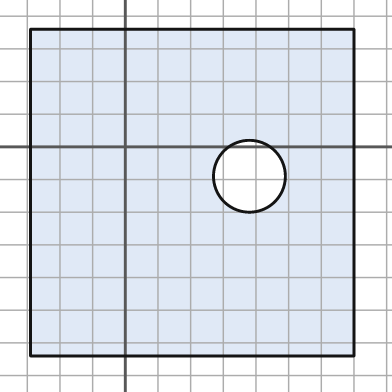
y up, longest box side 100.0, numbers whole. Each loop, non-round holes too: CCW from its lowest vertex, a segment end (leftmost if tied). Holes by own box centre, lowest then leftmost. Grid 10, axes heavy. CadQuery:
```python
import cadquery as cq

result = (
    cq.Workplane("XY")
    .moveTo(-29.0, -64.0)
    .lineTo(70.0, -64.0)
    .lineTo(70.0, 36.0)
    .lineTo(-29.0, 36.0)
    .close()
    .moveTo(38.0, -9.0)
    .circle(11.0)
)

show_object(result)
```